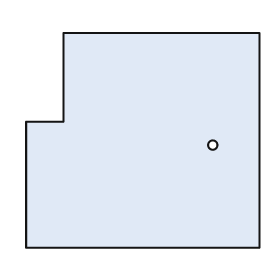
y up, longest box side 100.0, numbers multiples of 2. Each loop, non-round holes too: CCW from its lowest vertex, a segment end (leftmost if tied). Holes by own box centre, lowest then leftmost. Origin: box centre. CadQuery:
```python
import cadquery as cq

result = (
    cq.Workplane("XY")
    .moveTo(-50.0, -46.0)
    .lineTo(50.0, -46.0)
    .lineTo(50.0, 46.0)
    .lineTo(-34.0, 46.0)
    .lineTo(-34.0, 8.0)
    .lineTo(-50.0, 8.0)
    .close()
    .moveTo(30.0, -2.0)
    .circle(2.0)
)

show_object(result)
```